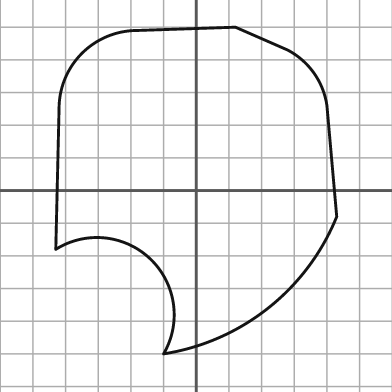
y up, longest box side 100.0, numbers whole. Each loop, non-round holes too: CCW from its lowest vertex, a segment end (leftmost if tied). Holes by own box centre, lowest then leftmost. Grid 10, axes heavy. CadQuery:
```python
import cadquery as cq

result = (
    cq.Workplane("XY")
    .moveTo(-10.0, -50.0)
    .threePointArc((22.0, -36.0), (43.0, -8.0))
    .lineTo(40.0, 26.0)
    .threePointArc((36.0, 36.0), (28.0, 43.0))
    .lineTo(12.0, 50.0)
    .lineTo(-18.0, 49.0)
    .threePointArc((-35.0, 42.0), (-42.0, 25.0))
    .lineTo(-43.0, -18.0)
    .threePointArc((-14.0, -21.0), (-10.0, -50.0))
    .close()
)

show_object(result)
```